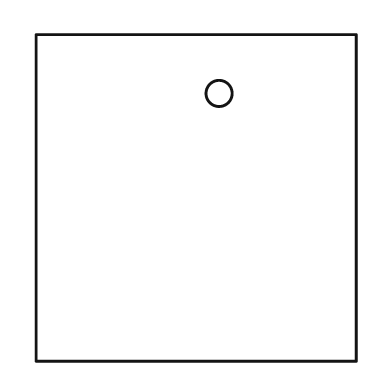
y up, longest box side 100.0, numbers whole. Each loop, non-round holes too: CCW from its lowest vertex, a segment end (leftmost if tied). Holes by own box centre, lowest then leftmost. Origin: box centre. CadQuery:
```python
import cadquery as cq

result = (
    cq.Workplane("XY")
    .moveTo(-49.0, -50.0)
    .lineTo(49.0, -50.0)
    .lineTo(49.0, 50.0)
    .lineTo(-49.0, 50.0)
    .close()
    .moveTo(7.0, 32.0)
    .circle(4.0)
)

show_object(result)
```